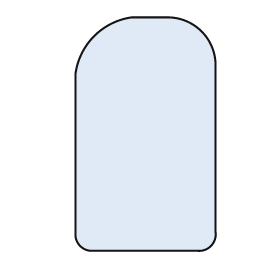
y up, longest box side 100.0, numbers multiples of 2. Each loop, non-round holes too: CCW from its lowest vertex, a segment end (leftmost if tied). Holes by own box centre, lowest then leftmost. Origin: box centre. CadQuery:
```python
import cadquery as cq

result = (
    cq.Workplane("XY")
    .moveTo(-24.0, -50.0)
    .lineTo(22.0, -50.0)
    .threePointArc((28.0, -48.0), (30.0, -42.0))
    .lineTo(30.0, 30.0)
    .threePointArc((24.0, 44.0), (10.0, 50.0))
    .lineTo(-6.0, 50.0)
    .threePointArc((-22.0, 42.0), (-30.0, 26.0))
    .lineTo(-30.0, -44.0)
    .threePointArc((-28.0, -48.0), (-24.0, -50.0))
    .close()
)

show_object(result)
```